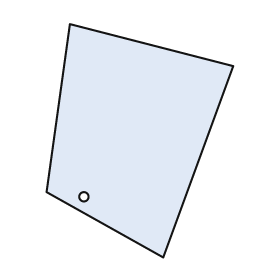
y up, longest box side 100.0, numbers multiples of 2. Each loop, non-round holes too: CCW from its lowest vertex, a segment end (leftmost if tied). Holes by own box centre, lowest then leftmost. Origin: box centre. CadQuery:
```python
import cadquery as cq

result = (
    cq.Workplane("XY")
    .moveTo(10.0, -50.0)
    .lineTo(40.0, 32.0)
    .lineTo(-30.0, 50.0)
    .lineTo(-40.0, -22.0)
    .close()
    .moveTo(-24.0, -24.0)
    .circle(2.0)
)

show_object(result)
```